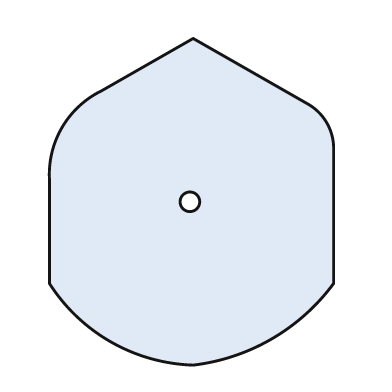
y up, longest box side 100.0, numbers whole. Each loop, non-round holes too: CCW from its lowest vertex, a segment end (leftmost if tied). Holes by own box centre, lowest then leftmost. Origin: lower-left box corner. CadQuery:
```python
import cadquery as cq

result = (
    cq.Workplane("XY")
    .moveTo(44.0, 0.0)
    .threePointArc((68.0, 8.0), (87.0, 25.0))
    .lineTo(87.0, 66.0)
    .threePointArc((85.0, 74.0), (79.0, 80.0))
    .lineTo(44.0, 100.0)
    .lineTo(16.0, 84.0)
    .threePointArc((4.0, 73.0), (0.0, 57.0))
    .lineTo(0.0, 25.0)
    .threePointArc((19.0, 7.0), (44.0, 0.0))
    .close()
    .moveTo(43.0, 50.0)
    .circle(3.0)
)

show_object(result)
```